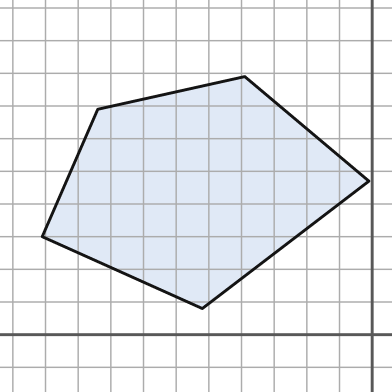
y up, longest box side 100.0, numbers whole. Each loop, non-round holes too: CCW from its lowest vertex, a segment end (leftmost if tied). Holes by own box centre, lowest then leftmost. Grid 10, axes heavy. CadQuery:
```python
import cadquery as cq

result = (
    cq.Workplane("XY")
    .moveTo(-52.0, 8.0)
    .lineTo(-1.0, 47.0)
    .lineTo(-39.0, 79.0)
    .lineTo(-84.0, 69.0)
    .lineTo(-101.0, 30.0)
    .close()
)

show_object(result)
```